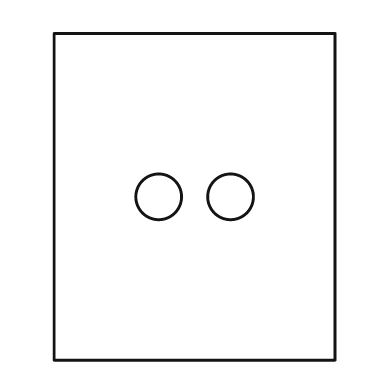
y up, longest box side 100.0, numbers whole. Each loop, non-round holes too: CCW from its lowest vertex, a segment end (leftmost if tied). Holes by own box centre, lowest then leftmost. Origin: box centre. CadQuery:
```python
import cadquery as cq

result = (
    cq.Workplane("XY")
    .moveTo(-43.0, -50.0)
    .lineTo(43.0, -50.0)
    .lineTo(43.0, 50.0)
    .lineTo(-43.0, 50.0)
    .close()
    .moveTo(-11.0, 0.0)
    .circle(7.0)
    .moveTo(11.0, 0.0)
    .circle(7.0)
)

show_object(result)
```